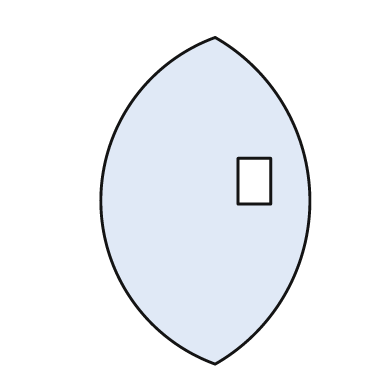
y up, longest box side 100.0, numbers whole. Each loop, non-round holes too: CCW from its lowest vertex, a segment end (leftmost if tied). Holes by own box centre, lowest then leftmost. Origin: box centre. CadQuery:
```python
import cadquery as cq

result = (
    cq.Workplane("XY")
    .moveTo(3.0, -50.0)
    .threePointArc((32.0, 0.0), (3.0, 50.0))
    .threePointArc((-32.0, 0.0), (3.0, -50.0))
    .close()
    .moveTo(10.0, -1.0)
    .lineTo(20.0, -1.0)
    .lineTo(20.0, 13.0)
    .lineTo(10.0, 13.0)
    .close()
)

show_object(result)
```